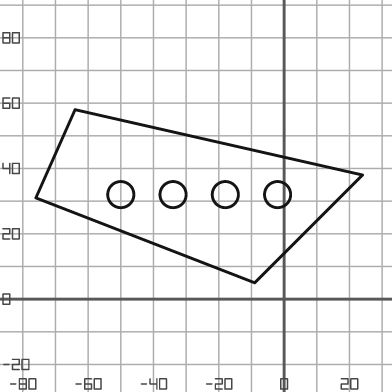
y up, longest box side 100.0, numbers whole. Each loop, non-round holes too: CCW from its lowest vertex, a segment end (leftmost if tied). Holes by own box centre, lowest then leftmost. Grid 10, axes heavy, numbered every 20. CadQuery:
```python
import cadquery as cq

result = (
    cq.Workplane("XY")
    .moveTo(-9.0, 5.0)
    .lineTo(24.0, 38.0)
    .lineTo(-64.0, 58.0)
    .lineTo(-76.0, 31.0)
    .close()
    .moveTo(-50.0, 32.0)
    .circle(4.0)
    .moveTo(-34.0, 32.0)
    .circle(4.0)
    .moveTo(-18.0, 32.0)
    .circle(4.0)
    .moveTo(-2.0, 32.0)
    .circle(4.0)
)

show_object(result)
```